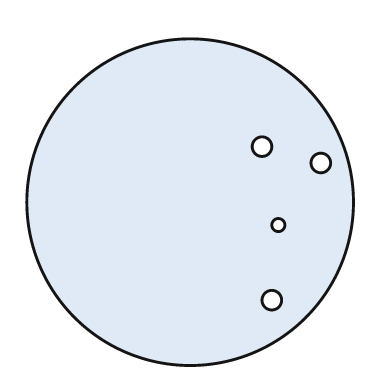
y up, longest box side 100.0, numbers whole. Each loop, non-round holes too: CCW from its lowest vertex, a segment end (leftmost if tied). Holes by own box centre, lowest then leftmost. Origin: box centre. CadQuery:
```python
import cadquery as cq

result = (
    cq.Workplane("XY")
    .moveTo(0.0, 0.0)
    .circle(50.0)
    .moveTo(25.0, -30.0)
    .circle(3.0)
    .moveTo(27.0, -7.0)
    .circle(2.0)
    .moveTo(40.0, 12.0)
    .circle(3.0)
    .moveTo(22.0, 17.0)
    .circle(3.0)
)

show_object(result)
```